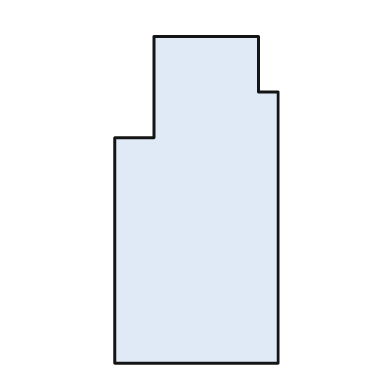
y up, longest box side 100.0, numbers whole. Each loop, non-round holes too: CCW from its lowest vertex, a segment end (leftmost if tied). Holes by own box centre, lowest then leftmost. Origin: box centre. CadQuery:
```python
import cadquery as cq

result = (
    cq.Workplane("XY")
    .moveTo(-25.0, -50.0)
    .lineTo(25.0, -50.0)
    .lineTo(25.0, 33.0)
    .lineTo(19.0, 33.0)
    .lineTo(19.0, 50.0)
    .lineTo(-13.0, 50.0)
    .lineTo(-13.0, 19.0)
    .lineTo(-25.0, 19.0)
    .close()
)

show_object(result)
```